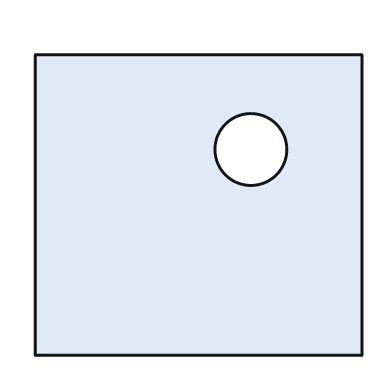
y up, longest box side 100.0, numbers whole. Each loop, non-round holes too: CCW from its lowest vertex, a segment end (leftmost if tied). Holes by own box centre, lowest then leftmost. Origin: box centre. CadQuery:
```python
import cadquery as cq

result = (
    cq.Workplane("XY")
    .moveTo(-50.0, -46.0)
    .lineTo(50.0, -46.0)
    .lineTo(50.0, 46.0)
    .lineTo(-50.0, 46.0)
    .close()
    .moveTo(16.0, 17.0)
    .circle(11.0)
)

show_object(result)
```